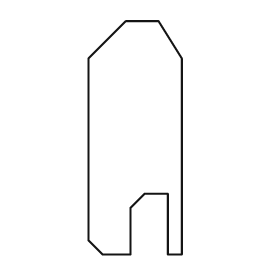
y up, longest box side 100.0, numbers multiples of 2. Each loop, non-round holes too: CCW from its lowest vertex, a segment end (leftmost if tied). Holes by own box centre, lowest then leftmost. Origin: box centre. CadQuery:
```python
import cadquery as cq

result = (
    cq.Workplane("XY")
    .moveTo(-14.0, -50.0)
    .lineTo(-2.0, -50.0)
    .lineTo(-2.0, -30.0)
    .lineTo(4.0, -24.0)
    .lineTo(14.0, -24.0)
    .lineTo(14.0, -50.0)
    .lineTo(20.0, -50.0)
    .lineTo(20.0, 34.0)
    .lineTo(10.0, 50.0)
    .lineTo(-4.0, 50.0)
    .lineTo(-20.0, 34.0)
    .lineTo(-20.0, -44.0)
    .close()
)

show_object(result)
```